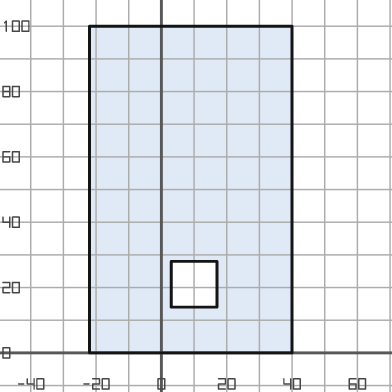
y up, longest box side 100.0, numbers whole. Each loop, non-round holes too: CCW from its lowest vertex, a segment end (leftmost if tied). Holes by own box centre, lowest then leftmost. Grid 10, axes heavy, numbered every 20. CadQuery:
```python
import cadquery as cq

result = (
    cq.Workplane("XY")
    .moveTo(-22.0, 0.0)
    .lineTo(40.0, 0.0)
    .lineTo(40.0, 100.0)
    .lineTo(-22.0, 100.0)
    .close()
    .moveTo(3.0, 14.0)
    .lineTo(17.0, 14.0)
    .lineTo(17.0, 28.0)
    .lineTo(3.0, 28.0)
    .close()
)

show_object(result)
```